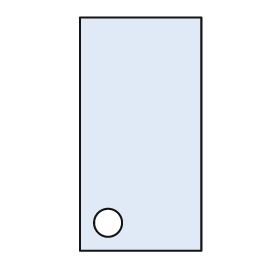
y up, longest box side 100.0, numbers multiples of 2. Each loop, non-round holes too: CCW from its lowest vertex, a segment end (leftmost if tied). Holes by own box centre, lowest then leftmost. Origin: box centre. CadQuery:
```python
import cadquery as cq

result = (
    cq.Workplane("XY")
    .moveTo(-26.0, -50.0)
    .lineTo(26.0, -50.0)
    .lineTo(26.0, 50.0)
    .lineTo(-26.0, 50.0)
    .close()
    .moveTo(-14.0, -38.0)
    .circle(6.0)
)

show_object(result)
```